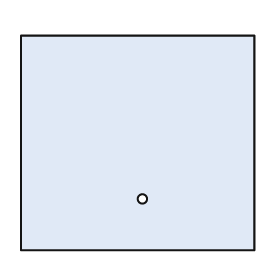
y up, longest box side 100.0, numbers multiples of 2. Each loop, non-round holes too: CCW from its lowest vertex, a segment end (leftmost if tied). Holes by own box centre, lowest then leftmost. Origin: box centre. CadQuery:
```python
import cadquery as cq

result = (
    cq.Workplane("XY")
    .moveTo(-50.0, -46.0)
    .lineTo(50.0, -46.0)
    .lineTo(50.0, 46.0)
    .lineTo(-50.0, 46.0)
    .close()
    .moveTo(2.0, -24.0)
    .circle(2.0)
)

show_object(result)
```